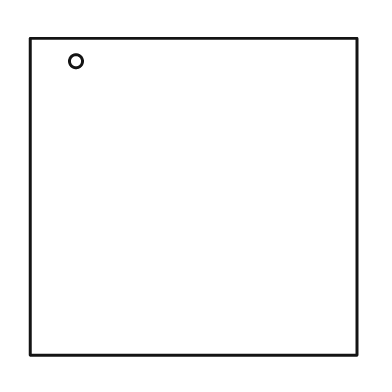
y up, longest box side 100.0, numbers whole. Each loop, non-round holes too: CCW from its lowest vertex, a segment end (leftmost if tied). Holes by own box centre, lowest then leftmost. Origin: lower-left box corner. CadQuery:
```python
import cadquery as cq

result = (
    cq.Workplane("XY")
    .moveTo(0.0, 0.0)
    .lineTo(100.0, 0.0)
    .lineTo(100.0, 97.0)
    .lineTo(0.0, 97.0)
    .close()
    .moveTo(14.0, 90.0)
    .circle(2.0)
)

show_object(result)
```